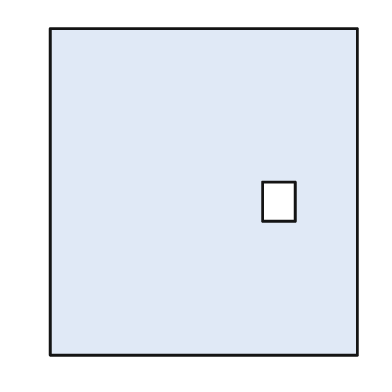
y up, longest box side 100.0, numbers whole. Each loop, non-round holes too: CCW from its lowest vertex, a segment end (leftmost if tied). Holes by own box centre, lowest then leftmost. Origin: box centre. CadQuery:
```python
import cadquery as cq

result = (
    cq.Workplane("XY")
    .moveTo(-47.0, -50.0)
    .lineTo(47.0, -50.0)
    .lineTo(47.0, 50.0)
    .lineTo(-47.0, 50.0)
    .close()
    .moveTo(18.0, -9.0)
    .lineTo(28.0, -9.0)
    .lineTo(28.0, 3.0)
    .lineTo(18.0, 3.0)
    .close()
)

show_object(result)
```